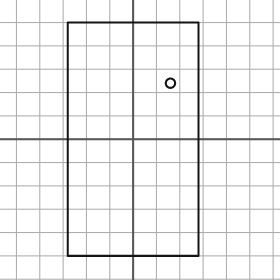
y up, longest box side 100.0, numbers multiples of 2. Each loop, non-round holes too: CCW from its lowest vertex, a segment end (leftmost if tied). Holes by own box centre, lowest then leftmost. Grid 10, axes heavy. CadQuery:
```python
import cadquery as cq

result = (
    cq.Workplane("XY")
    .moveTo(-28.0, -50.0)
    .lineTo(28.0, -50.0)
    .lineTo(28.0, 50.0)
    .lineTo(-28.0, 50.0)
    .close()
    .moveTo(16.0, 24.0)
    .circle(2.0)
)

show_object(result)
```